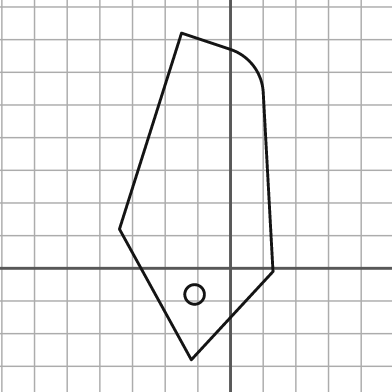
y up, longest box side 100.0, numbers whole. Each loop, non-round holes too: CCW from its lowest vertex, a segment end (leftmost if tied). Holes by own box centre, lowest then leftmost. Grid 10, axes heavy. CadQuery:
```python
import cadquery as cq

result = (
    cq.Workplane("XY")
    .moveTo(-12.0, -28.0)
    .lineTo(13.0, -1.0)
    .lineTo(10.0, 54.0)
    .threePointArc((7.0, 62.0), (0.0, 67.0))
    .lineTo(-15.0, 72.0)
    .lineTo(-34.0, 12.0)
    .close()
    .moveTo(-11.0, -8.0)
    .circle(3.0)
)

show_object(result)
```